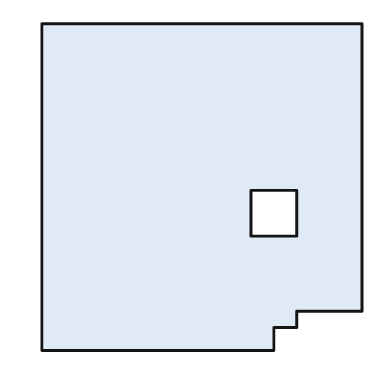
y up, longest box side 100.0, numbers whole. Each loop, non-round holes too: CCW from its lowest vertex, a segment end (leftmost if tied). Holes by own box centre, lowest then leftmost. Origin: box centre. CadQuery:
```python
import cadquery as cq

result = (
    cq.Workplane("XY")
    .moveTo(-49.0, -50.0)
    .lineTo(22.0, -50.0)
    .lineTo(22.0, -43.0)
    .lineTo(29.0, -43.0)
    .lineTo(29.0, -38.0)
    .lineTo(49.0, -38.0)
    .lineTo(49.0, 50.0)
    .lineTo(-49.0, 50.0)
    .close()
    .moveTo(15.0, -15.0)
    .lineTo(29.0, -15.0)
    .lineTo(29.0, -1.0)
    .lineTo(15.0, -1.0)
    .close()
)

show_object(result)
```